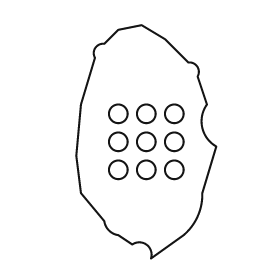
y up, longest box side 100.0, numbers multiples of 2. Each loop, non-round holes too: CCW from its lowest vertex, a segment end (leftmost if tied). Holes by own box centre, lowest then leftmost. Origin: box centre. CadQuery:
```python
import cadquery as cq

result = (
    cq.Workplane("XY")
    .moveTo(2.0, -50.0)
    .lineTo(16.0, -40.0)
    .threePointArc((22.0, -32.0), (24.0, -22.0))
    .lineTo(30.0, -2.0)
    .threePointArc((24.0, 6.0), (26.0, 16.0))
    .lineTo(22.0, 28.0)
    .threePointArc((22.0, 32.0), (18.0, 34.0))
    .lineTo(8.0, 44.0)
    .lineTo(-2.0, 50.0)
    .lineTo(-12.0, 48.0)
    .lineTo(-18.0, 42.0)
    .threePointArc((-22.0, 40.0), (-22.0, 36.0))
    .lineTo(-28.0, 16.0)
    .lineTo(-30.0, -6.0)
    .lineTo(-28.0, -22.0)
    .lineTo(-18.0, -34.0)
    .threePointArc((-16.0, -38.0), (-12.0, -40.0))
    .lineTo(-6.0, -44.0)
    .threePointArc((0.0, -44.0), (2.0, -50.0))
    .close()
    .moveTo(-12.0, -12.0)
    .circle(4.0)
    .moveTo(0.0, -12.0)
    .circle(4.0)
    .moveTo(12.0, -12.0)
    .circle(4.0)
    .moveTo(-12.0, 0.0)
    .circle(4.0)
    .moveTo(0.0, 0.0)
    .circle(4.0)
    .moveTo(12.0, 0.0)
    .circle(4.0)
    .moveTo(-12.0, 12.0)
    .circle(4.0)
    .moveTo(0.0, 12.0)
    .circle(4.0)
    .moveTo(12.0, 12.0)
    .circle(4.0)
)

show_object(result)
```